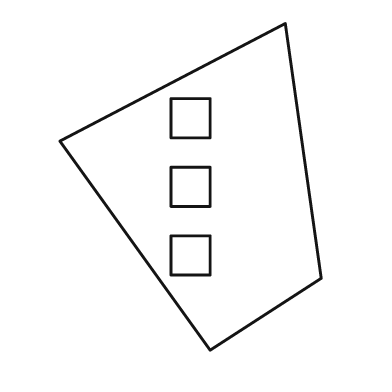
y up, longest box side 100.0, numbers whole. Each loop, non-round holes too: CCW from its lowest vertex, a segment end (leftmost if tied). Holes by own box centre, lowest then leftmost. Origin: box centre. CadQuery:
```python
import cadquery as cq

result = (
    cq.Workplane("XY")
    .moveTo(6.0, -50.0)
    .lineTo(40.0, -28.0)
    .lineTo(29.0, 50.0)
    .lineTo(-40.0, 14.0)
    .close()
    .moveTo(-6.0, -27.0)
    .lineTo(6.0, -27.0)
    .lineTo(6.0, -15.0)
    .lineTo(-6.0, -15.0)
    .close()
    .moveTo(-6.0, -6.0)
    .lineTo(6.0, -6.0)
    .lineTo(6.0, 6.0)
    .lineTo(-6.0, 6.0)
    .close()
    .moveTo(-6.0, 15.0)
    .lineTo(6.0, 15.0)
    .lineTo(6.0, 27.0)
    .lineTo(-6.0, 27.0)
    .close()
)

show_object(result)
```